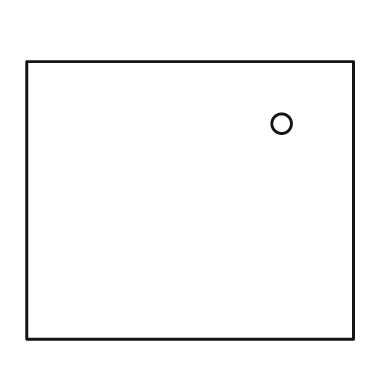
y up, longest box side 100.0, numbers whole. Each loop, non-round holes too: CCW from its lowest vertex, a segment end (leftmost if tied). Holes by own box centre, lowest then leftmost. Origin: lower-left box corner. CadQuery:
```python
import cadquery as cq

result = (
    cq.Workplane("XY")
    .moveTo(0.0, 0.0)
    .lineTo(100.0, 0.0)
    .lineTo(100.0, 85.0)
    .lineTo(0.0, 85.0)
    .close()
    .moveTo(78.0, 66.0)
    .circle(3.0)
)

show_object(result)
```